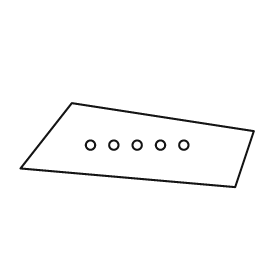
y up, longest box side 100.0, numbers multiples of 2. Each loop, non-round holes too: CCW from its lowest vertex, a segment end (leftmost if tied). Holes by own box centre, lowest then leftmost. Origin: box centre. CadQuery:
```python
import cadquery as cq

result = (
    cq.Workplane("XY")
    .moveTo(42.0, -18.0)
    .lineTo(50.0, 6.0)
    .lineTo(-28.0, 18.0)
    .lineTo(-50.0, -10.0)
    .close()
    .moveTo(-20.0, 0.0)
    .circle(2.0)
    .moveTo(-10.0, 0.0)
    .circle(2.0)
    .moveTo(0.0, 0.0)
    .circle(2.0)
    .moveTo(10.0, 0.0)
    .circle(2.0)
    .moveTo(20.0, 0.0)
    .circle(2.0)
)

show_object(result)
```